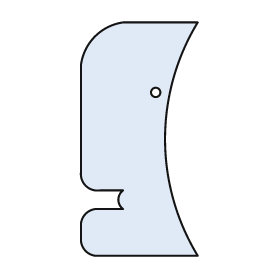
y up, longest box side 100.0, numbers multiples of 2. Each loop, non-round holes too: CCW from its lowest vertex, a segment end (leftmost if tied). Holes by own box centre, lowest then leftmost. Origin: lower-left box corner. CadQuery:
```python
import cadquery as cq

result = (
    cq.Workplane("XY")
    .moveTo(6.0, 0.0)
    .lineTo(50.0, 0.0)
    .threePointArc((36.0, 50.0), (50.0, 100.0))
    .lineTo(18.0, 100.0)
    .threePointArc((6.0, 94.0), (0.0, 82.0))
    .lineTo(0.0, 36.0)
    .threePointArc((2.0, 30.0), (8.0, 28.0))
    .lineTo(18.0, 28.0)
    .threePointArc((16.0, 24.0), (18.0, 20.0))
    .lineTo(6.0, 20.0)
    .threePointArc((2.0, 18.0), (0.0, 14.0))
    .lineTo(0.0, 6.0)
    .threePointArc((2.0, 2.0), (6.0, 0.0))
    .close()
    .moveTo(32.0, 70.0)
    .circle(2.0)
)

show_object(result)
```